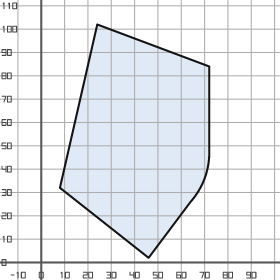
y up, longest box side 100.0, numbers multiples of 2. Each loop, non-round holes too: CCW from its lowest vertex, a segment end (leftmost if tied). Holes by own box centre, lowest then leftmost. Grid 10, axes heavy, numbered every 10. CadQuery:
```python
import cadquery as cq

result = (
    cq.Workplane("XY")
    .moveTo(46.0, 2.0)
    .lineTo(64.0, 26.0)
    .threePointArc((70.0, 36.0), (72.0, 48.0))
    .lineTo(72.0, 84.0)
    .lineTo(24.0, 102.0)
    .lineTo(8.0, 32.0)
    .close()
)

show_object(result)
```